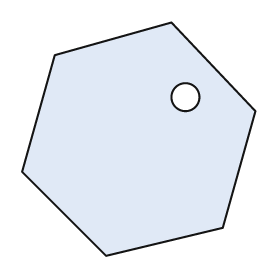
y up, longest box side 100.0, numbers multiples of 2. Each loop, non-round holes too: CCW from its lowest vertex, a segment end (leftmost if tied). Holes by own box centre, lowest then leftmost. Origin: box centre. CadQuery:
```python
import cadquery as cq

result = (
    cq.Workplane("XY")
    .moveTo(-14.0, -50.0)
    .lineTo(36.0, -38.0)
    .lineTo(50.0, 12.0)
    .lineTo(14.0, 50.0)
    .lineTo(-36.0, 36.0)
    .lineTo(-50.0, -14.0)
    .close()
    .moveTo(20.0, 18.0)
    .circle(6.0)
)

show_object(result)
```